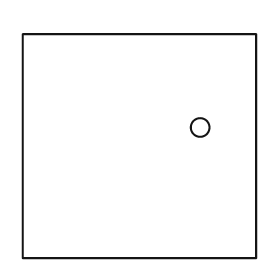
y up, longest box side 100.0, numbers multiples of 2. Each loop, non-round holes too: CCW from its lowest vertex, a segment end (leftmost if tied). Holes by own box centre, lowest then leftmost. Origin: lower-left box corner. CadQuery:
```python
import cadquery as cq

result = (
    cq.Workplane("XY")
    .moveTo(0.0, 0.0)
    .lineTo(100.0, 0.0)
    .lineTo(100.0, 96.0)
    .lineTo(0.0, 96.0)
    .close()
    .moveTo(76.0, 56.0)
    .circle(4.0)
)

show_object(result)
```